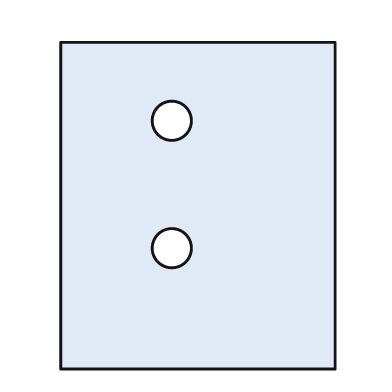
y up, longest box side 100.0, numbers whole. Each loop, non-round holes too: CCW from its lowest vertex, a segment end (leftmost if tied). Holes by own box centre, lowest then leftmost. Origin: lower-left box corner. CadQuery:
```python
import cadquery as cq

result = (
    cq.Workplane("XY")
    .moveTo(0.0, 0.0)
    .lineTo(84.0, 0.0)
    .lineTo(84.0, 100.0)
    .lineTo(0.0, 100.0)
    .close()
    .moveTo(34.0, 37.0)
    .circle(6.0)
    .moveTo(34.0, 76.0)
    .circle(6.0)
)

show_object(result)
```